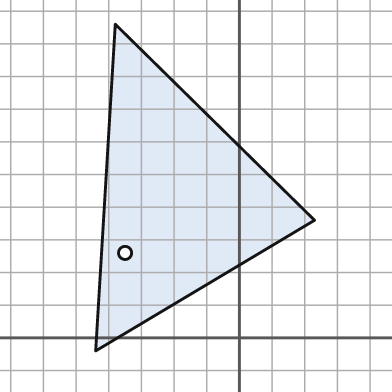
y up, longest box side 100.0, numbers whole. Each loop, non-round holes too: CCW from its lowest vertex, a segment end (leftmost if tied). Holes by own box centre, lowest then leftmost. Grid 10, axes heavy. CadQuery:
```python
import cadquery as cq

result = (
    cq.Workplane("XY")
    .moveTo(-44.0, -4.0)
    .lineTo(23.0, 36.0)
    .lineTo(-38.0, 96.0)
    .close()
    .moveTo(-35.0, 26.0)
    .circle(2.0)
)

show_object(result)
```